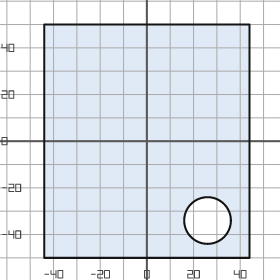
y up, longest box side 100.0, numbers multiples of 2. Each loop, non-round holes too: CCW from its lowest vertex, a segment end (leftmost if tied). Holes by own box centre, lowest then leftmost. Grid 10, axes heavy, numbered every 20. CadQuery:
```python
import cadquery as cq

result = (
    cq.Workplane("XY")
    .moveTo(-44.0, -50.0)
    .lineTo(44.0, -50.0)
    .lineTo(44.0, 50.0)
    .lineTo(-44.0, 50.0)
    .close()
    .moveTo(26.0, -34.0)
    .circle(10.0)
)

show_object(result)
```